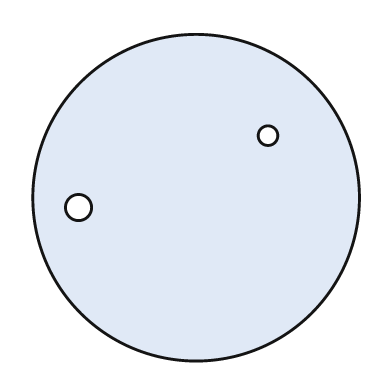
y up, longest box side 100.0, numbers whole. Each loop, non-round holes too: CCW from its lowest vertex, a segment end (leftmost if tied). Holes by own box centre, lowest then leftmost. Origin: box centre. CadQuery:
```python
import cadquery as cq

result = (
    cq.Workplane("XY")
    .moveTo(0.0, 0.0)
    .circle(50.0)
    .moveTo(-36.0, -3.0)
    .circle(4.0)
    .moveTo(22.0, 19.0)
    .circle(3.0)
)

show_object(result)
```